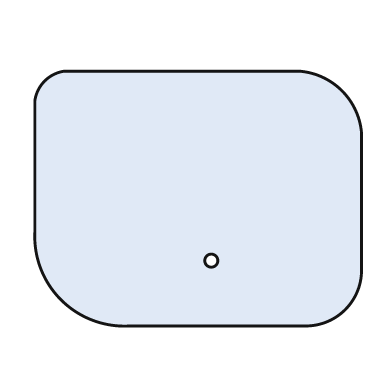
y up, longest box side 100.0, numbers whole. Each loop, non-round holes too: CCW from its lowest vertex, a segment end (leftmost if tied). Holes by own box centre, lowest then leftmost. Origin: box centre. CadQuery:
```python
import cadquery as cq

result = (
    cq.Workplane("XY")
    .moveTo(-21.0, -39.0)
    .lineTo(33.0, -39.0)
    .threePointArc((45.0, -34.0), (50.0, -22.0))
    .lineTo(50.0, 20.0)
    .threePointArc((44.0, 33.0), (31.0, 39.0))
    .lineTo(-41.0, 39.0)
    .threePointArc((-47.0, 36.0), (-50.0, 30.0))
    .lineTo(-50.0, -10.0)
    .threePointArc((-42.0, -31.0), (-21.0, -39.0))
    .close()
    .moveTo(4.0, -19.0)
    .circle(2.0)
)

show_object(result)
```